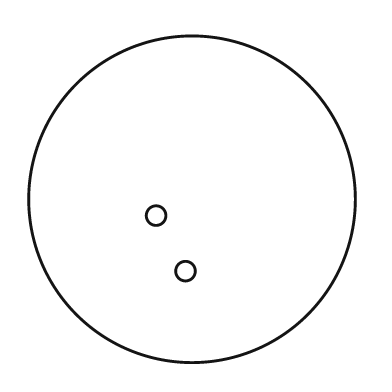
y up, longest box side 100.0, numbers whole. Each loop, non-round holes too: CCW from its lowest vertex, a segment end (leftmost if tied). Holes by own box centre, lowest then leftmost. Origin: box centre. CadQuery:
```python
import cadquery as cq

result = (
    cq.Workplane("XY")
    .moveTo(0.0, 0.0)
    .circle(50.0)
    .moveTo(-2.0, -22.0)
    .circle(3.0)
    .moveTo(-11.0, -5.0)
    .circle(3.0)
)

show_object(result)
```